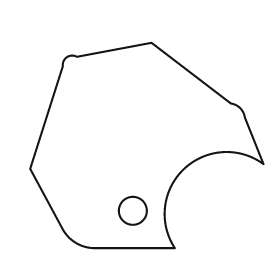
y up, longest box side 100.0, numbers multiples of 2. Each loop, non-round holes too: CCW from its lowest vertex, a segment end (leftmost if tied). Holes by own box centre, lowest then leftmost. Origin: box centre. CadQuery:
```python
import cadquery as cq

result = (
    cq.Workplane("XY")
    .moveTo(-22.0, -44.0)
    .lineTo(12.0, -44.0)
    .threePointArc((16.0, -10.0), (50.0, -8.0))
    .lineTo(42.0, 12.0)
    .threePointArc((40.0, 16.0), (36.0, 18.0))
    .lineTo(2.0, 44.0)
    .lineTo(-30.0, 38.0)
    .threePointArc((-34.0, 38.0), (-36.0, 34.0))
    .lineTo(-50.0, -10.0)
    .lineTo(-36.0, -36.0)
    .threePointArc((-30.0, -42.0), (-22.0, -44.0))
    .close()
    .moveTo(-6.0, -28.0)
    .circle(6.0)
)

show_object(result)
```